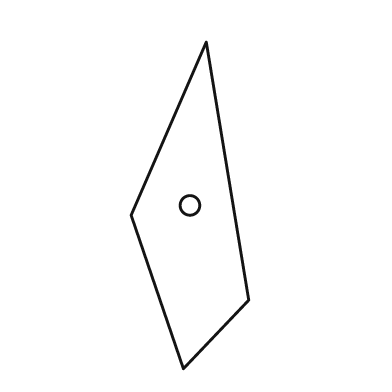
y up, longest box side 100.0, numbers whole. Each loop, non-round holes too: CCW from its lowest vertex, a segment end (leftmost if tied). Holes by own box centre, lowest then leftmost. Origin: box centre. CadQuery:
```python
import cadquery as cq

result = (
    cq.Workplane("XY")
    .moveTo(-2.0, -50.0)
    .lineTo(18.0, -29.0)
    .lineTo(5.0, 50.0)
    .lineTo(-18.0, -3.0)
    .close()
    .moveTo(0.0, 0.0)
    .circle(3.0)
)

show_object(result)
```